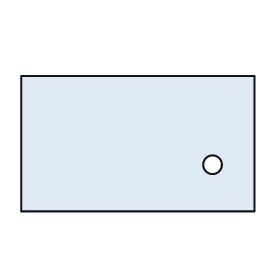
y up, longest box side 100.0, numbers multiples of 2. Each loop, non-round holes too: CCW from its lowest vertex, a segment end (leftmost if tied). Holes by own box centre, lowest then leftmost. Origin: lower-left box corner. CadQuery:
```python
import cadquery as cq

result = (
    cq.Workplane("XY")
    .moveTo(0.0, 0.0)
    .lineTo(100.0, 0.0)
    .lineTo(100.0, 58.0)
    .lineTo(0.0, 58.0)
    .close()
    .moveTo(82.0, 20.0)
    .circle(4.0)
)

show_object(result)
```